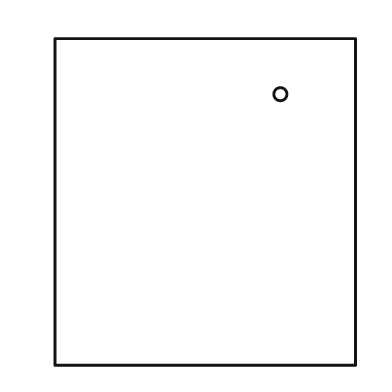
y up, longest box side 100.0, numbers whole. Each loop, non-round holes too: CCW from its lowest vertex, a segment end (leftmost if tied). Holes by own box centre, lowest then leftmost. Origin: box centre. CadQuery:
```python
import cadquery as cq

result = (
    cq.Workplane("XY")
    .moveTo(-46.0, -50.0)
    .lineTo(46.0, -50.0)
    .lineTo(46.0, 50.0)
    .lineTo(-46.0, 50.0)
    .close()
    .moveTo(23.0, 33.0)
    .circle(2.0)
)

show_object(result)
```